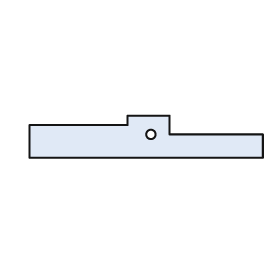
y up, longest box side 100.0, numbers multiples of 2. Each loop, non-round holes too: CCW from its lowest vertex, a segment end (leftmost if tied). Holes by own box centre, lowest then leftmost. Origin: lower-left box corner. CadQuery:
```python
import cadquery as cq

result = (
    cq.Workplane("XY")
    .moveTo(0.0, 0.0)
    .lineTo(100.0, 0.0)
    .lineTo(100.0, 10.0)
    .lineTo(60.0, 10.0)
    .lineTo(60.0, 18.0)
    .lineTo(42.0, 18.0)
    .lineTo(42.0, 14.0)
    .lineTo(0.0, 14.0)
    .close()
    .moveTo(52.0, 10.0)
    .circle(2.0)
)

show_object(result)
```